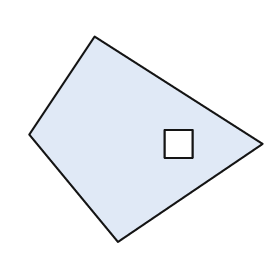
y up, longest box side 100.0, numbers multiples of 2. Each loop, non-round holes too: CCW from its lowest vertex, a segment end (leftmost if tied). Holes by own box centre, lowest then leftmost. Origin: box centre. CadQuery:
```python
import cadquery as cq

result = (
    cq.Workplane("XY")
    .moveTo(-12.0, -44.0)
    .lineTo(50.0, -2.0)
    .lineTo(-22.0, 44.0)
    .lineTo(-50.0, 2.0)
    .close()
    .moveTo(8.0, -8.0)
    .lineTo(20.0, -8.0)
    .lineTo(20.0, 4.0)
    .lineTo(8.0, 4.0)
    .close()
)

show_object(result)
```